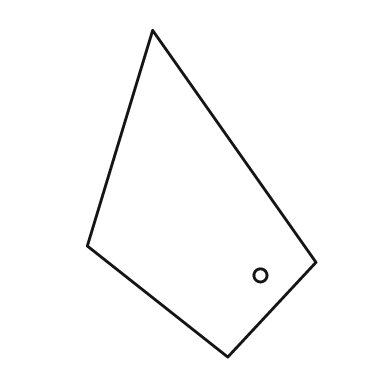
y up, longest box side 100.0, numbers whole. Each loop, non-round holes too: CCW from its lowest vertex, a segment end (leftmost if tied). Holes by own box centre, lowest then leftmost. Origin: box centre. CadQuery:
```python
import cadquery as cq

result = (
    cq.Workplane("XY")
    .moveTo(8.0, -50.0)
    .lineTo(35.0, -21.0)
    .lineTo(-15.0, 50.0)
    .lineTo(-35.0, -16.0)
    .close()
    .moveTo(18.0, -25.0)
    .circle(2.0)
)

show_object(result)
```